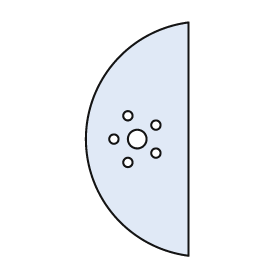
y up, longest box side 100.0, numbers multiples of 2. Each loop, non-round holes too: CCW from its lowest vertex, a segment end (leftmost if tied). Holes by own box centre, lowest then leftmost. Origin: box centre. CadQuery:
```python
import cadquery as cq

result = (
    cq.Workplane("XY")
    .moveTo(22.0, -50.0)
    .lineTo(22.0, 50.0)
    .threePointArc((-22.0, 0.0), (22.0, -50.0))
    .close()
    .moveTo(-4.0, -10.0)
    .circle(2.0)
    .moveTo(8.0, -6.0)
    .circle(2.0)
    .moveTo(-10.0, 0.0)
    .circle(2.0)
    .moveTo(0.0, 0.0)
    .circle(4.0)
    .moveTo(8.0, 6.0)
    .circle(2.0)
    .moveTo(-4.0, 10.0)
    .circle(2.0)
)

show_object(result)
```